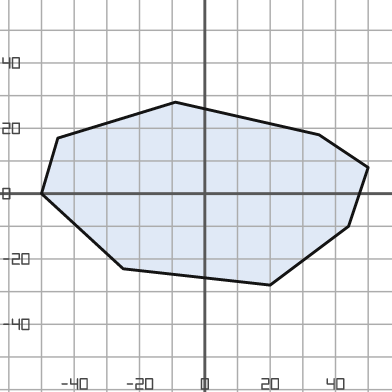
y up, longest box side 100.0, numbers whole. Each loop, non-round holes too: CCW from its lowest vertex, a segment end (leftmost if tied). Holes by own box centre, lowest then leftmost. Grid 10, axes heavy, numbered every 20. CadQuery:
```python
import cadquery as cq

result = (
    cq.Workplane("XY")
    .moveTo(20.0, -28.0)
    .lineTo(44.0, -10.0)
    .lineTo(50.0, 8.0)
    .lineTo(35.0, 18.0)
    .lineTo(-9.0, 28.0)
    .lineTo(-45.0, 17.0)
    .lineTo(-50.0, 0.0)
    .lineTo(-25.0, -23.0)
    .close()
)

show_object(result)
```